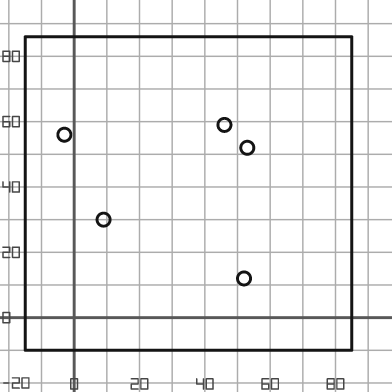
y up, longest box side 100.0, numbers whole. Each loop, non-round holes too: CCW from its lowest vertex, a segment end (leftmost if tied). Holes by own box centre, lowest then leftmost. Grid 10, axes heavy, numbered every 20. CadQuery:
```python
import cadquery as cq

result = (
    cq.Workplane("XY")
    .moveTo(-15.0, -10.0)
    .lineTo(85.0, -10.0)
    .lineTo(85.0, 86.0)
    .lineTo(-15.0, 86.0)
    .close()
    .moveTo(52.0, 12.0)
    .circle(2.0)
    .moveTo(9.0, 30.0)
    .circle(2.0)
    .moveTo(53.0, 52.0)
    .circle(2.0)
    .moveTo(-3.0, 56.0)
    .circle(2.0)
    .moveTo(46.0, 59.0)
    .circle(2.0)
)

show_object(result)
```